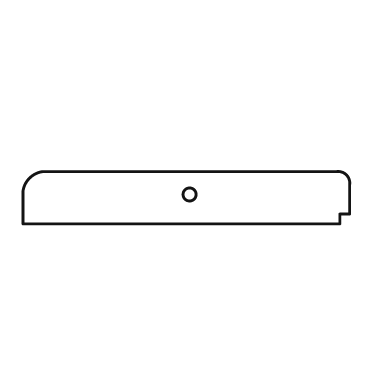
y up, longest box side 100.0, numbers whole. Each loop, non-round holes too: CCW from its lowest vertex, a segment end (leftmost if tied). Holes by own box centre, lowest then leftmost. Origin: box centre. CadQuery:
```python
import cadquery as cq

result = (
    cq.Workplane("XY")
    .moveTo(-50.0, -8.0)
    .lineTo(47.0, -8.0)
    .lineTo(47.0, -5.0)
    .lineTo(50.0, -5.0)
    .lineTo(50.0, 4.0)
    .threePointArc((49.0, 7.0), (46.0, 8.0))
    .lineTo(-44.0, 8.0)
    .threePointArc((-48.0, 6.0), (-50.0, 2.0))
    .close()
    .moveTo(1.0, 1.0)
    .circle(2.0)
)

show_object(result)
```